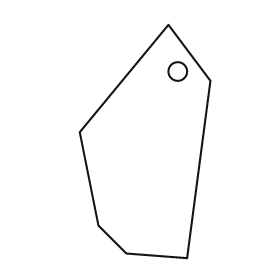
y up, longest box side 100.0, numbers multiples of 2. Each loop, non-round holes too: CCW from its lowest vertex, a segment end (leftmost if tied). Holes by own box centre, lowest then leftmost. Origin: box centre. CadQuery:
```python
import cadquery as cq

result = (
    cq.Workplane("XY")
    .moveTo(18.0, -50.0)
    .lineTo(28.0, 26.0)
    .lineTo(10.0, 50.0)
    .lineTo(-28.0, 4.0)
    .lineTo(-20.0, -36.0)
    .lineTo(-8.0, -48.0)
    .close()
    .moveTo(14.0, 30.0)
    .circle(4.0)
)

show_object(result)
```